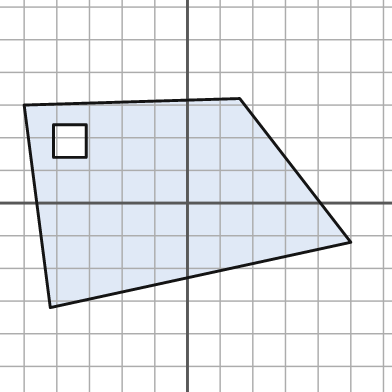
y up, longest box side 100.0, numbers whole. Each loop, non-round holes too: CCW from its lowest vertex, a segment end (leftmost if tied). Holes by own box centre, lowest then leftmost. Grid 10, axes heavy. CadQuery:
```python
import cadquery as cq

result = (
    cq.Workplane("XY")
    .moveTo(-42.0, -32.0)
    .lineTo(50.0, -12.0)
    .lineTo(16.0, 32.0)
    .lineTo(-50.0, 30.0)
    .close()
    .moveTo(-41.0, 14.0)
    .lineTo(-31.0, 14.0)
    .lineTo(-31.0, 24.0)
    .lineTo(-41.0, 24.0)
    .close()
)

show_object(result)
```